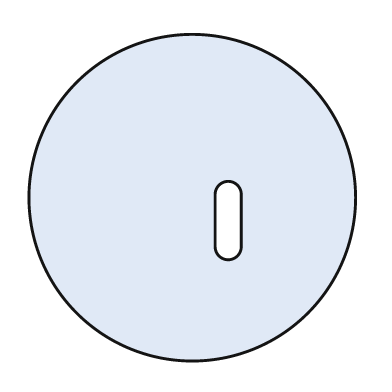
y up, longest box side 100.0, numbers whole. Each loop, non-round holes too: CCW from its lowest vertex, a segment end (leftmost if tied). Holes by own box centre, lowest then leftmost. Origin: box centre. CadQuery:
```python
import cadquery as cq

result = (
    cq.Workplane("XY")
    .moveTo(0.0, 0.0)
    .circle(50.0)
    .moveTo(7.0, -15.0)
    .threePointArc((11.0, -19.0), (15.0, -15.0))
    .lineTo(15.0, 1.0)
    .threePointArc((11.0, 5.0), (7.0, 1.0))
    .close()
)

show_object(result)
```